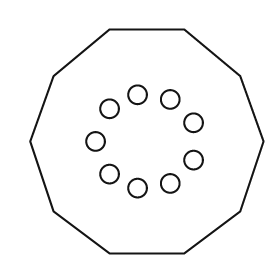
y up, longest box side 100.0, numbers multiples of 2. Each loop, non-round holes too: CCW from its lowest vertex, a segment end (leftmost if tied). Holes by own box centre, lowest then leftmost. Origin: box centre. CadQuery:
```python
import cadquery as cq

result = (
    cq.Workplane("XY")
    .moveTo(-16.0, -48.0)
    .lineTo(16.0, -48.0)
    .lineTo(40.0, -30.0)
    .lineTo(50.0, 0.0)
    .lineTo(40.0, 28.0)
    .lineTo(16.0, 48.0)
    .lineTo(-16.0, 48.0)
    .lineTo(-40.0, 28.0)
    .lineTo(-50.0, 0.0)
    .lineTo(-40.0, -30.0)
    .close()
    .moveTo(-4.0, -20.0)
    .circle(4.0)
    .moveTo(10.0, -18.0)
    .circle(4.0)
    .moveTo(-16.0, -14.0)
    .circle(4.0)
    .moveTo(20.0, -8.0)
    .circle(4.0)
    .moveTo(-22.0, 0.0)
    .circle(4.0)
    .moveTo(20.0, 8.0)
    .circle(4.0)
    .moveTo(-16.0, 14.0)
    .circle(4.0)
    .moveTo(10.0, 18.0)
    .circle(4.0)
    .moveTo(-4.0, 20.0)
    .circle(4.0)
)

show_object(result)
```